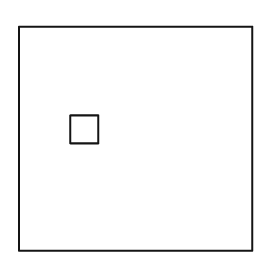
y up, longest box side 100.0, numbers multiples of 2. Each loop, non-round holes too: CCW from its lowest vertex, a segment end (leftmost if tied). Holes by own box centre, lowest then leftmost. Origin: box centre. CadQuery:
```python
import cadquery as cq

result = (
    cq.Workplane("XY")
    .moveTo(-50.0, -48.0)
    .lineTo(50.0, -48.0)
    .lineTo(50.0, 48.0)
    .lineTo(-50.0, 48.0)
    .close()
    .moveTo(-28.0, -2.0)
    .lineTo(-16.0, -2.0)
    .lineTo(-16.0, 10.0)
    .lineTo(-28.0, 10.0)
    .close()
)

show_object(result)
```